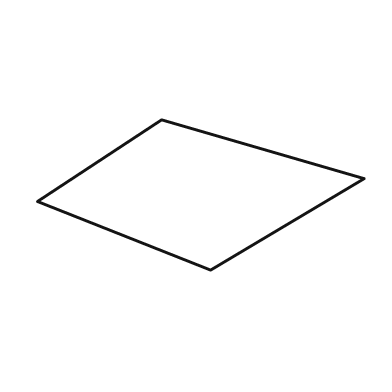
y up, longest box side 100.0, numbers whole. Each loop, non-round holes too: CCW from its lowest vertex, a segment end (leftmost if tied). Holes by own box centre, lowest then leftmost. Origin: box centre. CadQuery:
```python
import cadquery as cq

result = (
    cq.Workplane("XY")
    .moveTo(3.0, -23.0)
    .lineTo(50.0, 5.0)
    .lineTo(-12.0, 23.0)
    .lineTo(-50.0, -2.0)
    .close()
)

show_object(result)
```